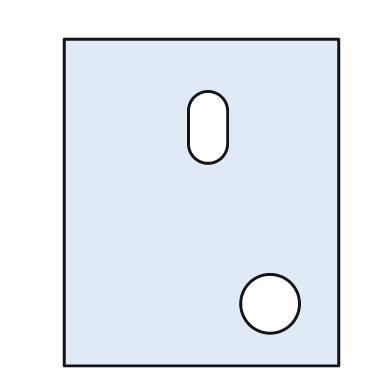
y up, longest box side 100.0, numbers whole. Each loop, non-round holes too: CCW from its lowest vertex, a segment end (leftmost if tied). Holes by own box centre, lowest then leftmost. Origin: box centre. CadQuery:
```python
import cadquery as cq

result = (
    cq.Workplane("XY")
    .moveTo(-42.0, -50.0)
    .lineTo(42.0, -50.0)
    .lineTo(42.0, 50.0)
    .lineTo(-42.0, 50.0)
    .close()
    .moveTo(21.0, -31.0)
    .circle(9.0)
    .moveTo(-4.0, 18.0)
    .threePointArc((2.0, 12.0), (8.0, 18.0))
    .lineTo(8.0, 28.0)
    .threePointArc((2.0, 34.0), (-4.0, 28.0))
    .close()
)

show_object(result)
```